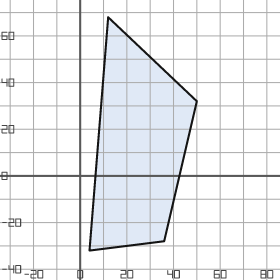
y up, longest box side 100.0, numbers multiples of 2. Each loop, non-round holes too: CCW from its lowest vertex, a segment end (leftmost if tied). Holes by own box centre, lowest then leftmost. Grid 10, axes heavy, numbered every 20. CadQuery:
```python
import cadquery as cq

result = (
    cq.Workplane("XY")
    .moveTo(4.0, -32.0)
    .lineTo(36.0, -28.0)
    .lineTo(50.0, 32.0)
    .lineTo(12.0, 68.0)
    .close()
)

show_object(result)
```